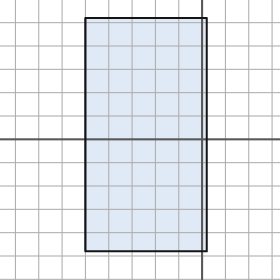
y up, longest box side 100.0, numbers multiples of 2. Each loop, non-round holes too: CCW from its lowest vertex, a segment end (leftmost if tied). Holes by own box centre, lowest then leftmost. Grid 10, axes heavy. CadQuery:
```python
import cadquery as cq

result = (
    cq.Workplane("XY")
    .moveTo(-50.0, -48.0)
    .lineTo(2.0, -48.0)
    .lineTo(2.0, 52.0)
    .lineTo(-50.0, 52.0)
    .close()
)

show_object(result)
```